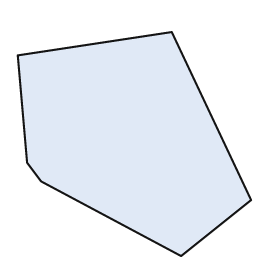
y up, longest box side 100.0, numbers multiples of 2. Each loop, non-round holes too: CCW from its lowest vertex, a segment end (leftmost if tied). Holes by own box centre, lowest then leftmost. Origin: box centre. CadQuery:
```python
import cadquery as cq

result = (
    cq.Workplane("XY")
    .moveTo(20.0, -48.0)
    .lineTo(50.0, -24.0)
    .lineTo(16.0, 48.0)
    .lineTo(-50.0, 38.0)
    .lineTo(-46.0, -8.0)
    .lineTo(-40.0, -16.0)
    .close()
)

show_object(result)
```